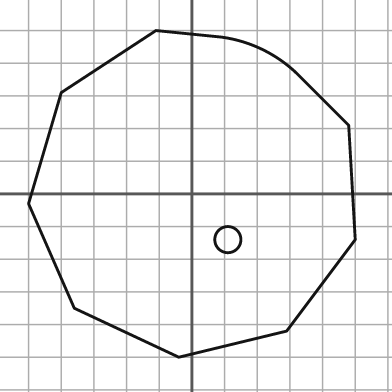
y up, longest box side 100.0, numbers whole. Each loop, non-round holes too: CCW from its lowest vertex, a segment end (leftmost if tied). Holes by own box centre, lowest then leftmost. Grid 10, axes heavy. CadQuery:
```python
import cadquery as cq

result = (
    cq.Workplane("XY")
    .moveTo(-4.0, -50.0)
    .lineTo(29.0, -42.0)
    .lineTo(50.0, -14.0)
    .lineTo(48.0, 21.0)
    .lineTo(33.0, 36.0)
    .threePointArc((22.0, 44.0), (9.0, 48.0))
    .lineTo(-11.0, 50.0)
    .lineTo(-40.0, 31.0)
    .lineTo(-50.0, -3.0)
    .lineTo(-36.0, -35.0)
    .close()
    .moveTo(11.0, -14.0)
    .circle(4.0)
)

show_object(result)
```